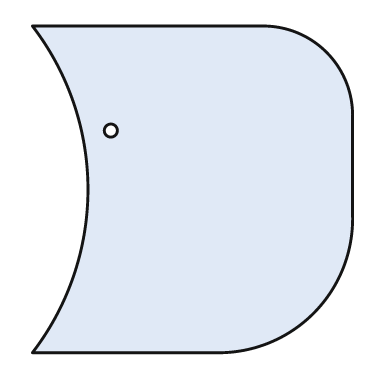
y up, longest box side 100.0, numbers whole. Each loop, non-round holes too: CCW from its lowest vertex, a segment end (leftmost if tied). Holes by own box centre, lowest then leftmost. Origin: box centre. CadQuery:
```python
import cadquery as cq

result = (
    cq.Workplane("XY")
    .moveTo(-49.0, -50.0)
    .lineTo(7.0, -50.0)
    .threePointArc((37.0, -38.0), (49.0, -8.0))
    .lineTo(49.0, 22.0)
    .threePointArc((41.0, 42.0), (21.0, 50.0))
    .lineTo(-49.0, 50.0)
    .threePointArc((-32.0, 0.0), (-49.0, -50.0))
    .close()
    .moveTo(-25.0, 18.0)
    .circle(2.0)
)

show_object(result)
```